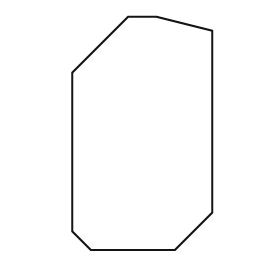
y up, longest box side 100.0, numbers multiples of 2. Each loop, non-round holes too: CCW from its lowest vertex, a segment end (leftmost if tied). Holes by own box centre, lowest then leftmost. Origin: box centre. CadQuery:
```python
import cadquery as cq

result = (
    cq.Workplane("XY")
    .moveTo(-22.0, -50.0)
    .lineTo(14.0, -50.0)
    .lineTo(30.0, -34.0)
    .lineTo(30.0, 44.0)
    .lineTo(6.0, 50.0)
    .lineTo(-6.0, 50.0)
    .lineTo(-30.0, 26.0)
    .lineTo(-30.0, -42.0)
    .close()
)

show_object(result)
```